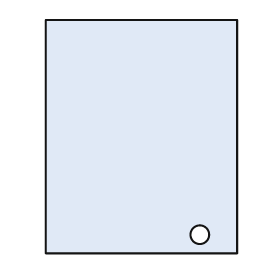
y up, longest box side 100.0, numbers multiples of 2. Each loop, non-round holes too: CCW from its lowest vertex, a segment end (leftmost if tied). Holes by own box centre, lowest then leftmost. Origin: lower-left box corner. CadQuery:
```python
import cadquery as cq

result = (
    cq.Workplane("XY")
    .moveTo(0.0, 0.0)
    .lineTo(82.0, 0.0)
    .lineTo(82.0, 100.0)
    .lineTo(0.0, 100.0)
    .close()
    .moveTo(66.0, 8.0)
    .circle(4.0)
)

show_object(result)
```